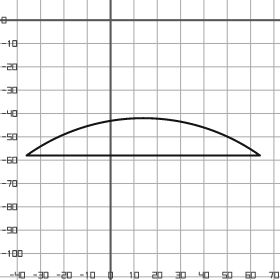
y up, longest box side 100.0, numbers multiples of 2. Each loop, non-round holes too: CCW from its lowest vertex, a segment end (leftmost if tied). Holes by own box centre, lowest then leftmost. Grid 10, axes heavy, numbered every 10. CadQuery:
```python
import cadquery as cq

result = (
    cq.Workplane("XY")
    .moveTo(-36.0, -58.0)
    .lineTo(64.0, -58.0)
    .threePointArc((14.0, -42.0), (-36.0, -58.0))
    .close()
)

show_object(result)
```